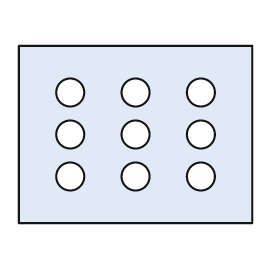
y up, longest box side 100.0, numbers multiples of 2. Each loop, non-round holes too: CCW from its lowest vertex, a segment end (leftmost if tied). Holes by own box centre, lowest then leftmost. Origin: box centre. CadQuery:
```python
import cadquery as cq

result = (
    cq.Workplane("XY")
    .moveTo(-50.0, -38.0)
    .lineTo(50.0, -38.0)
    .lineTo(50.0, 38.0)
    .lineTo(-50.0, 38.0)
    .close()
    .moveTo(-28.0, -18.0)
    .circle(6.0)
    .moveTo(0.0, -18.0)
    .circle(6.0)
    .moveTo(28.0, -18.0)
    .circle(6.0)
    .moveTo(-28.0, 0.0)
    .circle(6.0)
    .moveTo(0.0, 0.0)
    .circle(6.0)
    .moveTo(28.0, 0.0)
    .circle(6.0)
    .moveTo(-28.0, 18.0)
    .circle(6.0)
    .moveTo(0.0, 18.0)
    .circle(6.0)
    .moveTo(28.0, 18.0)
    .circle(6.0)
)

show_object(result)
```